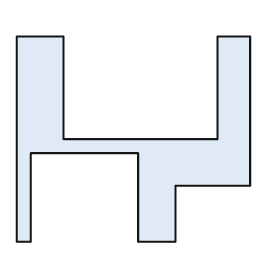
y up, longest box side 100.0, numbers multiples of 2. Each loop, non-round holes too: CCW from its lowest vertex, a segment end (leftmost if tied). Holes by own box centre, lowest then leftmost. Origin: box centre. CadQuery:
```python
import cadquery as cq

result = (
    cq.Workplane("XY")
    .moveTo(-50.0, -44.0)
    .lineTo(-44.0, -44.0)
    .lineTo(-44.0, -6.0)
    .lineTo(2.0, -6.0)
    .lineTo(2.0, -44.0)
    .lineTo(18.0, -44.0)
    .lineTo(18.0, -20.0)
    .lineTo(50.0, -20.0)
    .lineTo(50.0, 44.0)
    .lineTo(36.0, 44.0)
    .lineTo(36.0, 0.0)
    .lineTo(-30.0, 0.0)
    .lineTo(-30.0, 44.0)
    .lineTo(-50.0, 44.0)
    .close()
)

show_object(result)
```